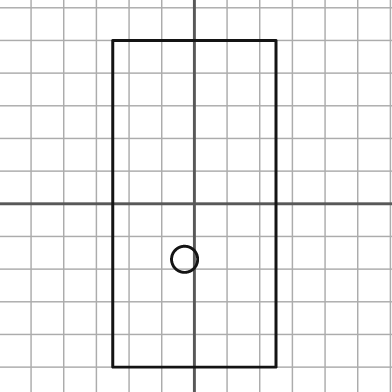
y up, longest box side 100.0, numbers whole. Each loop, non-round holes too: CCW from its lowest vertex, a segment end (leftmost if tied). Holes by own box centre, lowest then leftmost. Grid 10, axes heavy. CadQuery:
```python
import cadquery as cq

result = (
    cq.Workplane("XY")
    .moveTo(-25.0, -50.0)
    .lineTo(25.0, -50.0)
    .lineTo(25.0, 50.0)
    .lineTo(-25.0, 50.0)
    .close()
    .moveTo(-3.0, -17.0)
    .circle(4.0)
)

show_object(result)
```